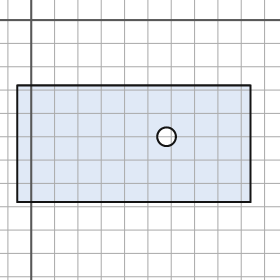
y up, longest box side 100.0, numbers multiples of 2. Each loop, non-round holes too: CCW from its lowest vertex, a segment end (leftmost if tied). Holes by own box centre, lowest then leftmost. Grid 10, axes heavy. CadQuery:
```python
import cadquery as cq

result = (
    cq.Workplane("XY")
    .moveTo(-6.0, -78.0)
    .lineTo(94.0, -78.0)
    .lineTo(94.0, -28.0)
    .lineTo(-6.0, -28.0)
    .close()
    .moveTo(58.0, -50.0)
    .circle(4.0)
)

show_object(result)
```